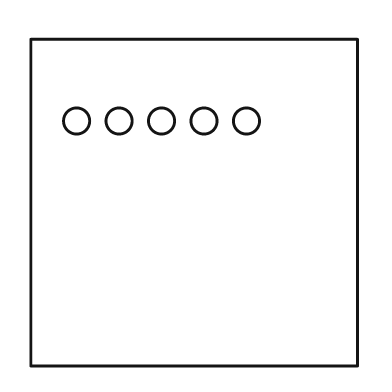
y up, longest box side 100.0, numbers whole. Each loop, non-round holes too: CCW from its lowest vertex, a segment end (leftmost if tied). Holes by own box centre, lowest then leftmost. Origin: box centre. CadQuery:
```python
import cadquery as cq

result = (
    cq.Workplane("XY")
    .moveTo(-50.0, -50.0)
    .lineTo(50.0, -50.0)
    .lineTo(50.0, 50.0)
    .lineTo(-50.0, 50.0)
    .close()
    .moveTo(-36.0, 25.0)
    .circle(4.0)
    .moveTo(-23.0, 25.0)
    .circle(4.0)
    .moveTo(-10.0, 25.0)
    .circle(4.0)
    .moveTo(3.0, 25.0)
    .circle(4.0)
    .moveTo(16.0, 25.0)
    .circle(4.0)
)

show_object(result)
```